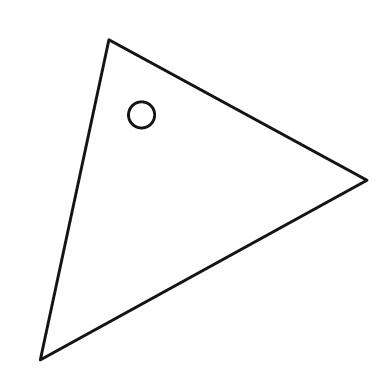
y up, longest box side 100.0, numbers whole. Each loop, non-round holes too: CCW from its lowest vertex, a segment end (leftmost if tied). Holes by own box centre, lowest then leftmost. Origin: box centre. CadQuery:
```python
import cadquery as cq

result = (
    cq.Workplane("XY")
    .moveTo(-50.0, -49.0)
    .lineTo(50.0, 6.0)
    .lineTo(-29.0, 49.0)
    .close()
    .moveTo(-19.0, 26.0)
    .circle(4.0)
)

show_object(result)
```